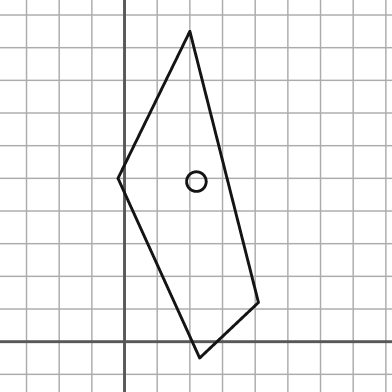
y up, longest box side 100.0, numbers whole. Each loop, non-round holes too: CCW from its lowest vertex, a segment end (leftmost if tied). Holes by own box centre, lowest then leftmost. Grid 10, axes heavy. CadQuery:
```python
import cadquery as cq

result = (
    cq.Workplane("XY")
    .moveTo(23.0, -5.0)
    .lineTo(41.0, 12.0)
    .lineTo(20.0, 95.0)
    .lineTo(-2.0, 50.0)
    .close()
    .moveTo(22.0, 49.0)
    .circle(3.0)
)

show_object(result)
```